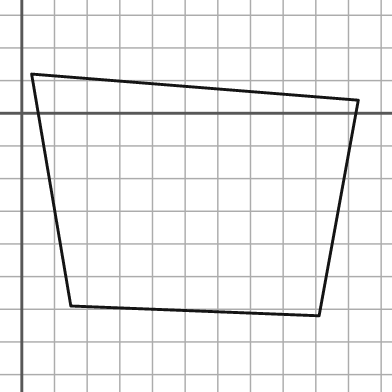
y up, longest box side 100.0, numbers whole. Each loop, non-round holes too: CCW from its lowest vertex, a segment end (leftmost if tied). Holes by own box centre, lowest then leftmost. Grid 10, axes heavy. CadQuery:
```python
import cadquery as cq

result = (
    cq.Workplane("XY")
    .moveTo(91.0, -62.0)
    .lineTo(103.0, 4.0)
    .lineTo(3.0, 12.0)
    .lineTo(15.0, -59.0)
    .close()
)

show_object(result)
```